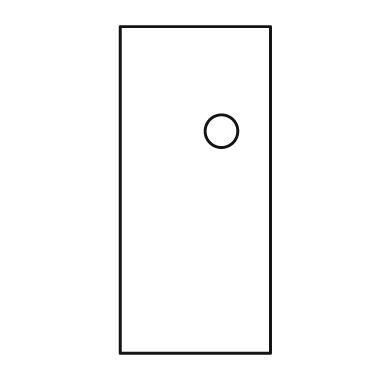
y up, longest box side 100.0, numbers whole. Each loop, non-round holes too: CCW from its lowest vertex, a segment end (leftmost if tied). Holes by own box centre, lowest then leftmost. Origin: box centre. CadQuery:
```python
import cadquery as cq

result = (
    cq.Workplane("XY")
    .moveTo(-23.0, -50.0)
    .lineTo(23.0, -50.0)
    .lineTo(23.0, 50.0)
    .lineTo(-23.0, 50.0)
    .close()
    .moveTo(8.0, 18.0)
    .circle(5.0)
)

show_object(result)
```